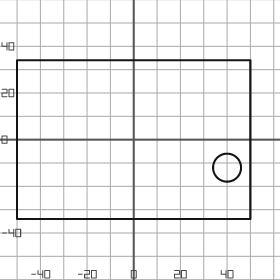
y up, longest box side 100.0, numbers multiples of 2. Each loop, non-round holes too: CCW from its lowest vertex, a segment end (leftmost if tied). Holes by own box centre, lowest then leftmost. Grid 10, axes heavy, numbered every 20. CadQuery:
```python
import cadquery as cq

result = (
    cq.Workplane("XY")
    .moveTo(-50.0, -34.0)
    .lineTo(50.0, -34.0)
    .lineTo(50.0, 34.0)
    .lineTo(-50.0, 34.0)
    .close()
    .moveTo(40.0, -12.0)
    .circle(6.0)
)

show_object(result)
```